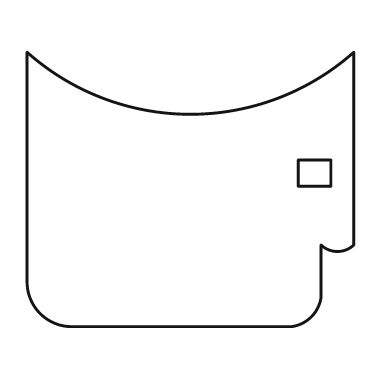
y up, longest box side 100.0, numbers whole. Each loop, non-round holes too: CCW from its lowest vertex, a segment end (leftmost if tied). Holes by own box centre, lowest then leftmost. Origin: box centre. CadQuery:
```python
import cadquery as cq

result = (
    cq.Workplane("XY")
    .moveTo(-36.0, -42.0)
    .lineTo(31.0, -42.0)
    .threePointArc((37.0, -39.0), (40.0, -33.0))
    .lineTo(40.0, -17.0)
    .threePointArc((45.0, -19.0), (50.0, -17.0))
    .lineTo(50.0, 42.0)
    .threePointArc((0.0, 23.0), (-50.0, 42.0))
    .lineTo(-50.0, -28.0)
    .threePointArc((-46.0, -38.0), (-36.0, -42.0))
    .close()
    .moveTo(33.0, 1.0)
    .lineTo(43.0, 1.0)
    .lineTo(43.0, 9.0)
    .lineTo(33.0, 9.0)
    .close()
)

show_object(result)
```